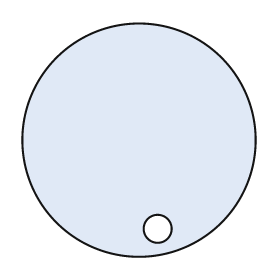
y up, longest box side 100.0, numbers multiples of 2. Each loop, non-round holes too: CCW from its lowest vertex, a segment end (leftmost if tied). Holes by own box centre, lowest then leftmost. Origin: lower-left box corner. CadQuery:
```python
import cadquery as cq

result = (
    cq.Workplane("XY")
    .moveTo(50.0, 50.0)
    .circle(50.0)
    .moveTo(58.0, 12.0)
    .circle(6.0)
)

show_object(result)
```